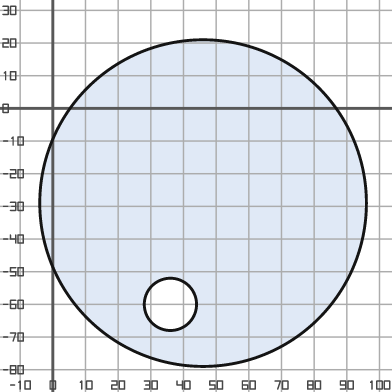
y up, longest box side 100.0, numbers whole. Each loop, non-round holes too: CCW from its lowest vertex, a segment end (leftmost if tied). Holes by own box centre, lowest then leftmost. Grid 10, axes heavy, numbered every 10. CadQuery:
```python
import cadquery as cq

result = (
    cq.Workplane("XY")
    .moveTo(46.0, -29.0)
    .circle(50.0)
    .moveTo(36.0, -60.0)
    .circle(8.0)
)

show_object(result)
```